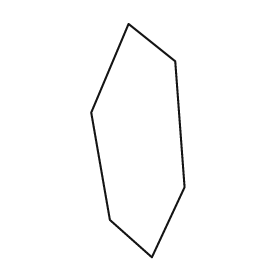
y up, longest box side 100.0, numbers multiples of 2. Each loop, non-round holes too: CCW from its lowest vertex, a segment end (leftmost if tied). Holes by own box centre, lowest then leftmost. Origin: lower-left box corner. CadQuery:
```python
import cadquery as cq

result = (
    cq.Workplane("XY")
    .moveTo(26.0, 0.0)
    .lineTo(40.0, 30.0)
    .lineTo(36.0, 84.0)
    .lineTo(16.0, 100.0)
    .lineTo(0.0, 62.0)
    .lineTo(8.0, 16.0)
    .close()
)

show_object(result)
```